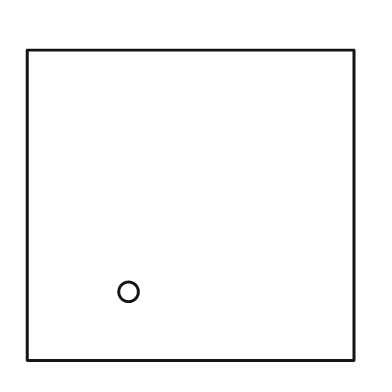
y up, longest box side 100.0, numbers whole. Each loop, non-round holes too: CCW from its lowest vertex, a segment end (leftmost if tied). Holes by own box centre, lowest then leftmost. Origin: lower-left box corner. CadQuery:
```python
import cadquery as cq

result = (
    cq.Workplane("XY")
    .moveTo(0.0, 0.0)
    .lineTo(100.0, 0.0)
    .lineTo(100.0, 95.0)
    .lineTo(0.0, 95.0)
    .close()
    .moveTo(31.0, 21.0)
    .circle(3.0)
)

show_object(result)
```